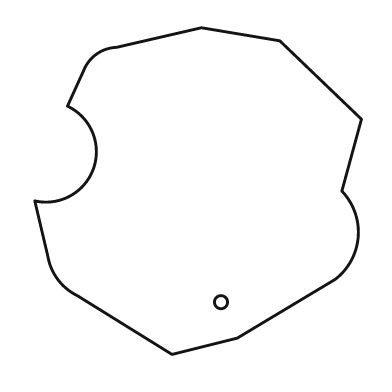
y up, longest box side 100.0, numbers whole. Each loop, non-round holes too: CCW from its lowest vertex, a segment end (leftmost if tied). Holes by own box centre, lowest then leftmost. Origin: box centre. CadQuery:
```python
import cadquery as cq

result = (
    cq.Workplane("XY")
    .moveTo(-8.0, -50.0)
    .lineTo(12.0, -45.0)
    .lineTo(42.0, -27.0)
    .threePointArc((49.0, -14.0), (44.0, 0.0))
    .lineTo(50.0, 22.0)
    .lineTo(25.0, 46.0)
    .lineTo(1.0, 50.0)
    .lineTo(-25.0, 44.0)
    .threePointArc((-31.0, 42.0), (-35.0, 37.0))
    .lineTo(-40.0, 26.0)
    .threePointArc((-32.0, 7.0), (-50.0, -3.0))
    .lineTo(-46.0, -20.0)
    .threePointArc((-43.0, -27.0), (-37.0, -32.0))
    .close()
    .moveTo(7.0, -34.0)
    .circle(2.0)
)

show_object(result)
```